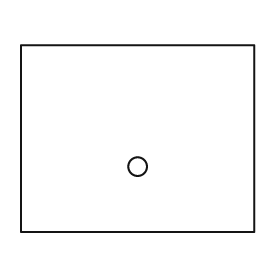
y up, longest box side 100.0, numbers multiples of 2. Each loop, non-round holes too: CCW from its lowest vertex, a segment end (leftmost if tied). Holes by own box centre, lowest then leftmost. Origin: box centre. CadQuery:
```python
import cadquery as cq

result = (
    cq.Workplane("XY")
    .moveTo(-50.0, -40.0)
    .lineTo(50.0, -40.0)
    .lineTo(50.0, 40.0)
    .lineTo(-50.0, 40.0)
    .close()
    .moveTo(0.0, -12.0)
    .circle(4.0)
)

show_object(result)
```